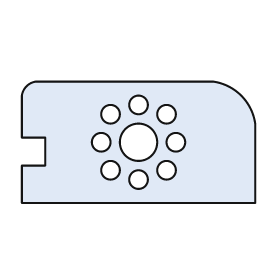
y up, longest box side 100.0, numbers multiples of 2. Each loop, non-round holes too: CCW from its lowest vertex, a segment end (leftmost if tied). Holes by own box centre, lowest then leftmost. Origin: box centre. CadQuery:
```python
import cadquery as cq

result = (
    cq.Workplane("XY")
    .moveTo(-50.0, -26.0)
    .lineTo(50.0, -26.0)
    .lineTo(50.0, 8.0)
    .threePointArc((44.0, 20.0), (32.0, 26.0))
    .lineTo(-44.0, 26.0)
    .threePointArc((-48.0, 24.0), (-50.0, 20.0))
    .lineTo(-50.0, 2.0)
    .lineTo(-40.0, 2.0)
    .lineTo(-40.0, -10.0)
    .lineTo(-50.0, -10.0)
    .close()
    .moveTo(0.0, -16.0)
    .circle(4.0)
    .moveTo(-12.0, -12.0)
    .circle(4.0)
    .moveTo(12.0, -12.0)
    .circle(4.0)
    .moveTo(-16.0, 0.0)
    .circle(4.0)
    .moveTo(0.0, 0.0)
    .circle(8.0)
    .moveTo(16.0, 0.0)
    .circle(4.0)
    .moveTo(-12.0, 12.0)
    .circle(4.0)
    .moveTo(12.0, 12.0)
    .circle(4.0)
    .moveTo(0.0, 16.0)
    .circle(4.0)
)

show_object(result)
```